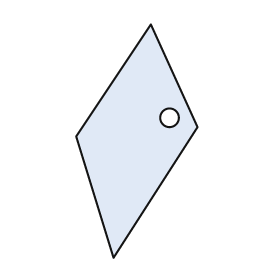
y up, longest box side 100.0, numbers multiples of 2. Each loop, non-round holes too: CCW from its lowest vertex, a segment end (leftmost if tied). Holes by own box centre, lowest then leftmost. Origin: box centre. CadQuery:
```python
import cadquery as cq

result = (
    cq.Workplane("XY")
    .moveTo(-10.0, -50.0)
    .lineTo(26.0, 6.0)
    .lineTo(6.0, 50.0)
    .lineTo(-26.0, 2.0)
    .close()
    .moveTo(14.0, 10.0)
    .circle(4.0)
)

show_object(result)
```